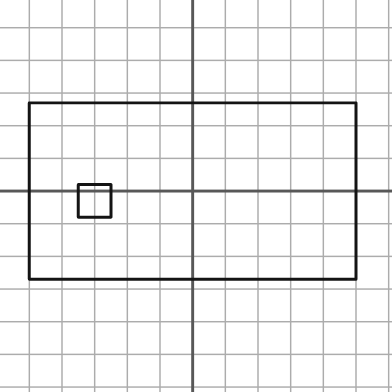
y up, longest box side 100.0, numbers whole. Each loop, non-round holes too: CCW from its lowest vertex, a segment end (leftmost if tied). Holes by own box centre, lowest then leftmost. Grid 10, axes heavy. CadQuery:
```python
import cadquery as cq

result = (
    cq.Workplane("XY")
    .moveTo(-50.0, -27.0)
    .lineTo(50.0, -27.0)
    .lineTo(50.0, 27.0)
    .lineTo(-50.0, 27.0)
    .close()
    .moveTo(-35.0, -8.0)
    .lineTo(-25.0, -8.0)
    .lineTo(-25.0, 2.0)
    .lineTo(-35.0, 2.0)
    .close()
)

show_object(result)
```